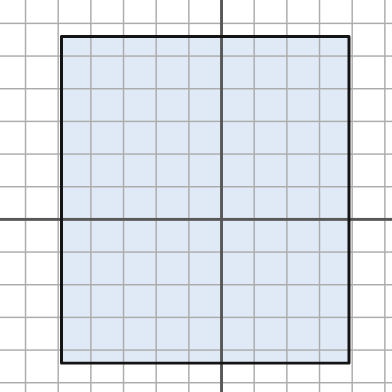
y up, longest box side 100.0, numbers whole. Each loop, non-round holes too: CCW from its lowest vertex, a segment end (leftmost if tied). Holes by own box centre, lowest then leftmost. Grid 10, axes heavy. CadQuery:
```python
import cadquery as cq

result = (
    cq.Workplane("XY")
    .moveTo(-49.0, -44.0)
    .lineTo(39.0, -44.0)
    .lineTo(39.0, 56.0)
    .lineTo(-49.0, 56.0)
    .close()
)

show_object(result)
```